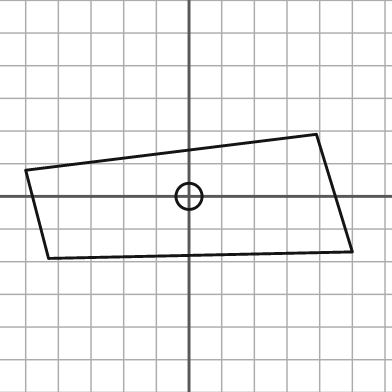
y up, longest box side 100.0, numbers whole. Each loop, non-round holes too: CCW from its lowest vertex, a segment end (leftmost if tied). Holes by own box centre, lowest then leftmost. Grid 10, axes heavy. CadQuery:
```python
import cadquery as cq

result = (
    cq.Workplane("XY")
    .moveTo(-43.0, -19.0)
    .lineTo(50.0, -17.0)
    .lineTo(39.0, 19.0)
    .lineTo(-50.0, 8.0)
    .close()
    .moveTo(0.0, 0.0)
    .circle(4.0)
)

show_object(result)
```